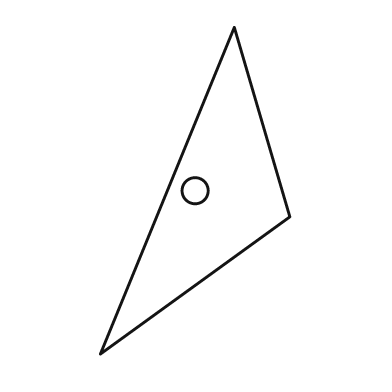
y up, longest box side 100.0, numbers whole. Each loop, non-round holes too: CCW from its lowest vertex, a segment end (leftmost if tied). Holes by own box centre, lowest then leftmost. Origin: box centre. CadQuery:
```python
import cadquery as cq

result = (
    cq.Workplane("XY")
    .moveTo(-29.0, -50.0)
    .lineTo(29.0, -8.0)
    .lineTo(12.0, 50.0)
    .close()
    .moveTo(0.0, 0.0)
    .circle(4.0)
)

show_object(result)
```